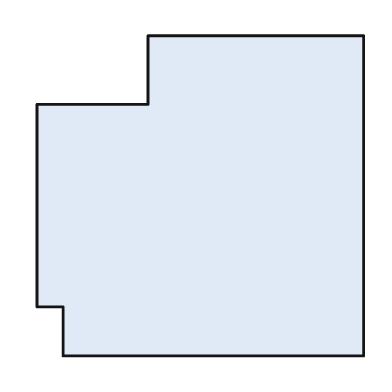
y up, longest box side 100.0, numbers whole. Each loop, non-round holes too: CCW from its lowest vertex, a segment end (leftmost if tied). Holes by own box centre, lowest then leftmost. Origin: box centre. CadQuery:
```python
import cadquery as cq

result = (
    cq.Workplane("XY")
    .moveTo(-42.0, -49.0)
    .lineTo(50.0, -49.0)
    .lineTo(50.0, 49.0)
    .lineTo(-16.0, 49.0)
    .lineTo(-16.0, 28.0)
    .lineTo(-50.0, 28.0)
    .lineTo(-50.0, -34.0)
    .lineTo(-42.0, -34.0)
    .close()
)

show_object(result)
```